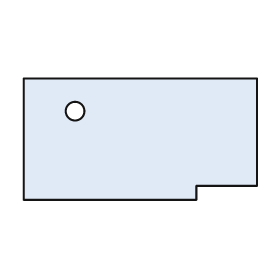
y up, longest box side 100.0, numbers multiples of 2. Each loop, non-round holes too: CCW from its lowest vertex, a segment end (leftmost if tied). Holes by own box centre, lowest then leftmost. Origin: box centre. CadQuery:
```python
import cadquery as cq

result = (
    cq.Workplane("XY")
    .moveTo(-50.0, -26.0)
    .lineTo(24.0, -26.0)
    .lineTo(24.0, -20.0)
    .lineTo(50.0, -20.0)
    .lineTo(50.0, 26.0)
    .lineTo(-50.0, 26.0)
    .close()
    .moveTo(-28.0, 12.0)
    .circle(4.0)
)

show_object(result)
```